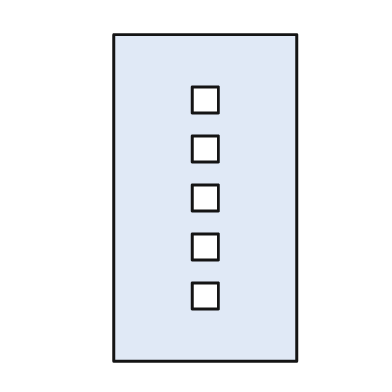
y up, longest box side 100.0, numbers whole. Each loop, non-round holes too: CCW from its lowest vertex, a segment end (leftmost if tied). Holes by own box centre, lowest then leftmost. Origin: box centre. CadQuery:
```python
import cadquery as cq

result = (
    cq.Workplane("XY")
    .moveTo(-28.0, -50.0)
    .lineTo(28.0, -50.0)
    .lineTo(28.0, 50.0)
    .lineTo(-28.0, 50.0)
    .close()
    .moveTo(-4.0, -34.0)
    .lineTo(4.0, -34.0)
    .lineTo(4.0, -26.0)
    .lineTo(-4.0, -26.0)
    .close()
    .moveTo(-4.0, -19.0)
    .lineTo(4.0, -19.0)
    .lineTo(4.0, -11.0)
    .lineTo(-4.0, -11.0)
    .close()
    .moveTo(-4.0, -4.0)
    .lineTo(4.0, -4.0)
    .lineTo(4.0, 4.0)
    .lineTo(-4.0, 4.0)
    .close()
    .moveTo(-4.0, 11.0)
    .lineTo(4.0, 11.0)
    .lineTo(4.0, 19.0)
    .lineTo(-4.0, 19.0)
    .close()
    .moveTo(-4.0, 26.0)
    .lineTo(4.0, 26.0)
    .lineTo(4.0, 34.0)
    .lineTo(-4.0, 34.0)
    .close()
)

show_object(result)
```